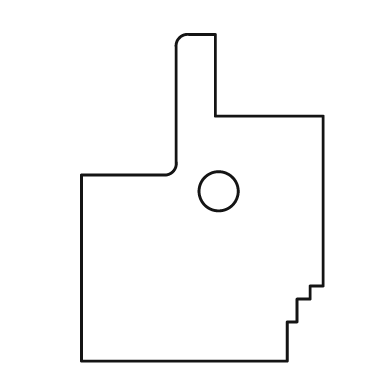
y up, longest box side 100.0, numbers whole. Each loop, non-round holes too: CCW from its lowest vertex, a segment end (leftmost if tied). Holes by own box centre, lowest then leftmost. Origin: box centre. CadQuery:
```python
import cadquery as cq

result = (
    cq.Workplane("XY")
    .moveTo(-37.0, -50.0)
    .lineTo(26.0, -50.0)
    .lineTo(26.0, -38.0)
    .lineTo(29.0, -38.0)
    .lineTo(29.0, -31.0)
    .lineTo(33.0, -31.0)
    .lineTo(33.0, -27.0)
    .lineTo(37.0, -27.0)
    .lineTo(37.0, 25.0)
    .lineTo(4.0, 25.0)
    .lineTo(4.0, 50.0)
    .lineTo(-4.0, 50.0)
    .threePointArc((-7.0, 49.0), (-8.0, 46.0))
    .lineTo(-8.0, 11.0)
    .threePointArc((-9.0, 8.0), (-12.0, 7.0))
    .lineTo(-37.0, 7.0)
    .close()
    .moveTo(5.0, 2.0)
    .circle(6.0)
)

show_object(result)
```